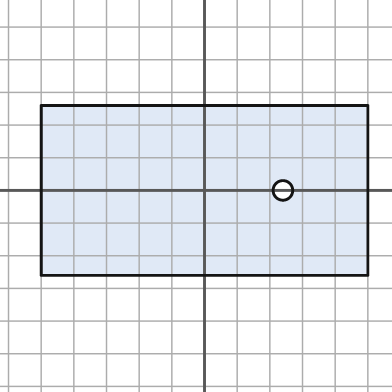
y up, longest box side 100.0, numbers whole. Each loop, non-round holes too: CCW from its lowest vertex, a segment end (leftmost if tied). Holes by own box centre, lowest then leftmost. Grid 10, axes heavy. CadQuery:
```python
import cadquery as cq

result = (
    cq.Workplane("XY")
    .moveTo(-50.0, -26.0)
    .lineTo(50.0, -26.0)
    .lineTo(50.0, 26.0)
    .lineTo(-50.0, 26.0)
    .close()
    .moveTo(24.0, 0.0)
    .circle(3.0)
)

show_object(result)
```